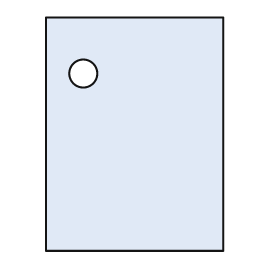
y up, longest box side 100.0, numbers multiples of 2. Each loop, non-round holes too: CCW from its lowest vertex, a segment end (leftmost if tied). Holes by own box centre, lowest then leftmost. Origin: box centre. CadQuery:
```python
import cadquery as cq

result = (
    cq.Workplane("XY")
    .moveTo(-38.0, -50.0)
    .lineTo(38.0, -50.0)
    .lineTo(38.0, 50.0)
    .lineTo(-38.0, 50.0)
    .close()
    .moveTo(-22.0, 26.0)
    .circle(6.0)
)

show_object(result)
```